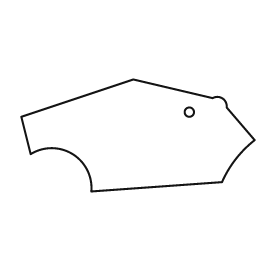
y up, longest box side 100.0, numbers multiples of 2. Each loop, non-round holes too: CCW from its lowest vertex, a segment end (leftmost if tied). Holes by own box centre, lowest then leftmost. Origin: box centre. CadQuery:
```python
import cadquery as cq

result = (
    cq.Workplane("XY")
    .moveTo(-20.0, -24.0)
    .lineTo(36.0, -20.0)
    .threePointArc((42.0, -10.0), (50.0, -2.0))
    .lineTo(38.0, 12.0)
    .threePointArc((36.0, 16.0), (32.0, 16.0))
    .lineTo(-2.0, 24.0)
    .lineTo(-50.0, 8.0)
    .lineTo(-46.0, -8.0)
    .threePointArc((-28.0, -8.0), (-20.0, -24.0))
    .close()
    .moveTo(22.0, 10.0)
    .circle(2.0)
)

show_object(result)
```